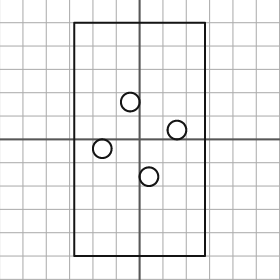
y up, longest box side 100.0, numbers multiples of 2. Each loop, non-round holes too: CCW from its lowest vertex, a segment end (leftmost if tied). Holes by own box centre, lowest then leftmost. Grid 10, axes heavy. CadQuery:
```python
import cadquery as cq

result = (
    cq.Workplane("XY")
    .moveTo(-28.0, -50.0)
    .lineTo(28.0, -50.0)
    .lineTo(28.0, 50.0)
    .lineTo(-28.0, 50.0)
    .close()
    .moveTo(4.0, -16.0)
    .circle(4.0)
    .moveTo(-16.0, -4.0)
    .circle(4.0)
    .moveTo(16.0, 4.0)
    .circle(4.0)
    .moveTo(-4.0, 16.0)
    .circle(4.0)
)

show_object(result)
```